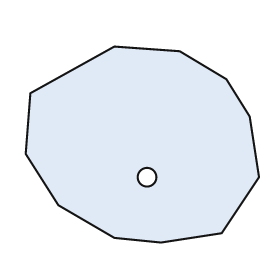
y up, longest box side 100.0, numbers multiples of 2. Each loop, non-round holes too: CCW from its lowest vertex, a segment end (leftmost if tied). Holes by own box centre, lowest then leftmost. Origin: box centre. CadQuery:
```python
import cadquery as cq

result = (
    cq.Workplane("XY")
    .moveTo(8.0, -42.0)
    .lineTo(34.0, -38.0)
    .lineTo(50.0, -14.0)
    .lineTo(46.0, 12.0)
    .lineTo(36.0, 28.0)
    .lineTo(16.0, 40.0)
    .lineTo(-12.0, 42.0)
    .lineTo(-48.0, 22.0)
    .lineTo(-50.0, -4.0)
    .lineTo(-36.0, -26.0)
    .lineTo(-12.0, -40.0)
    .close()
    .moveTo(2.0, -14.0)
    .circle(4.0)
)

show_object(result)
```